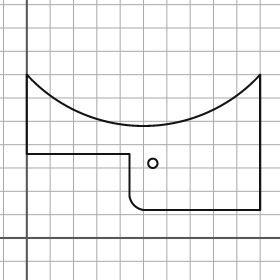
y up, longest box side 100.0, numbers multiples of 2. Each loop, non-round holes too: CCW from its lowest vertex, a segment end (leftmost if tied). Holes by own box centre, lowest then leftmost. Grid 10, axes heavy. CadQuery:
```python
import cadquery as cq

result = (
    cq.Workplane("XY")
    .moveTo(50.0, 12.0)
    .lineTo(100.0, 12.0)
    .lineTo(100.0, 70.0)
    .threePointArc((50.0, 48.0), (0.0, 70.0))
    .lineTo(0.0, 36.0)
    .lineTo(44.0, 36.0)
    .lineTo(44.0, 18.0)
    .threePointArc((46.0, 14.0), (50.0, 12.0))
    .close()
    .moveTo(54.0, 32.0)
    .circle(2.0)
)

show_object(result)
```